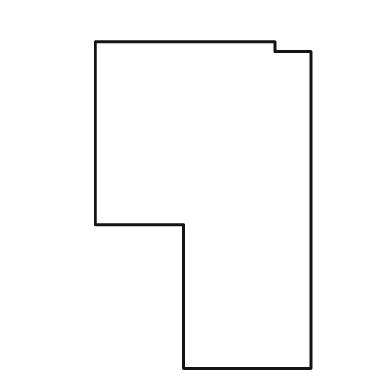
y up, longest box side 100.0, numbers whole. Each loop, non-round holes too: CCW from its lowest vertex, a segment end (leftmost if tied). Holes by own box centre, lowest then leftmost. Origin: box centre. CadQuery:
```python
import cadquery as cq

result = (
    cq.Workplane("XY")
    .moveTo(-6.0, -50.0)
    .lineTo(33.0, -50.0)
    .lineTo(33.0, 47.0)
    .lineTo(22.0, 47.0)
    .lineTo(22.0, 50.0)
    .lineTo(-33.0, 50.0)
    .lineTo(-33.0, -6.0)
    .lineTo(-6.0, -6.0)
    .close()
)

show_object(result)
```